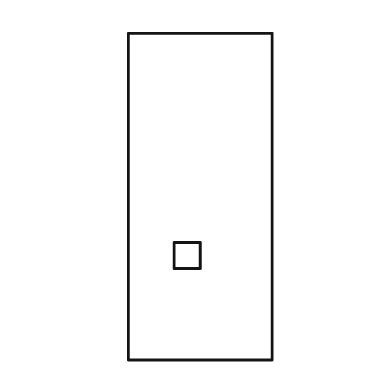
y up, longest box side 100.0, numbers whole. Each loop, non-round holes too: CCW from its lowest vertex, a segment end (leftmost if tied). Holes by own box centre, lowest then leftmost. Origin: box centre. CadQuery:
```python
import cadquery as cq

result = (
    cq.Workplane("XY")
    .moveTo(-22.0, -50.0)
    .lineTo(22.0, -50.0)
    .lineTo(22.0, 50.0)
    .lineTo(-22.0, 50.0)
    .close()
    .moveTo(-8.0, -22.0)
    .lineTo(0.0, -22.0)
    .lineTo(0.0, -14.0)
    .lineTo(-8.0, -14.0)
    .close()
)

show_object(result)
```